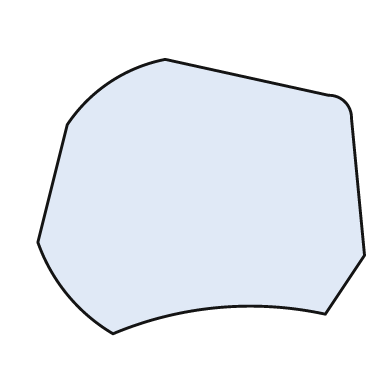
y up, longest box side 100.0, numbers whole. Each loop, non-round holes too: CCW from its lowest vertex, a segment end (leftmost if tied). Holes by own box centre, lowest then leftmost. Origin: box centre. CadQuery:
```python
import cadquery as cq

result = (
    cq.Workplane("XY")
    .moveTo(-27.0, -42.0)
    .threePointArc((5.0, -34.0), (38.0, -36.0))
    .lineTo(50.0, -18.0)
    .lineTo(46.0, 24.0)
    .threePointArc((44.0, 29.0), (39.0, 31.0))
    .lineTo(-11.0, 42.0)
    .threePointArc((-28.0, 35.0), (-41.0, 22.0))
    .lineTo(-50.0, -14.0)
    .threePointArc((-41.0, -30.0), (-27.0, -42.0))
    .close()
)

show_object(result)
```